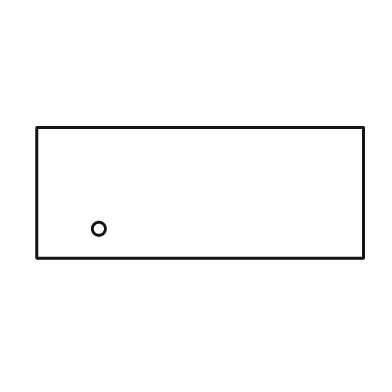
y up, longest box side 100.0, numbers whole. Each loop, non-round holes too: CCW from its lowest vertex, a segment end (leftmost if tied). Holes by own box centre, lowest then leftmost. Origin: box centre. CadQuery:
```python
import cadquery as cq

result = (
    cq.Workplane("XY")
    .moveTo(-50.0, -20.0)
    .lineTo(50.0, -20.0)
    .lineTo(50.0, 20.0)
    .lineTo(-50.0, 20.0)
    .close()
    .moveTo(-31.0, -11.0)
    .circle(2.0)
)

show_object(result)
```